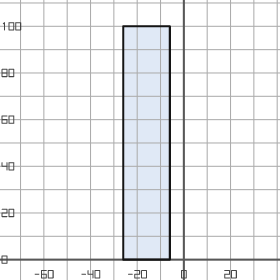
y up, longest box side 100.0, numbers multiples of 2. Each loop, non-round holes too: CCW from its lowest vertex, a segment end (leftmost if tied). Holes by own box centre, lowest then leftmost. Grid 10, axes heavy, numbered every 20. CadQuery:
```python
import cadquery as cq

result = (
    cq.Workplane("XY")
    .moveTo(-26.0, 0.0)
    .lineTo(-6.0, 0.0)
    .lineTo(-6.0, 100.0)
    .lineTo(-26.0, 100.0)
    .close()
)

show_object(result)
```